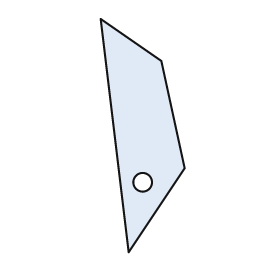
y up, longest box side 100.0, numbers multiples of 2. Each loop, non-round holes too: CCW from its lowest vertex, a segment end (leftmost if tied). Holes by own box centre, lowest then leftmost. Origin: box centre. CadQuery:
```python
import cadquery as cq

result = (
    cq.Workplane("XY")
    .moveTo(-6.0, -50.0)
    .lineTo(18.0, -14.0)
    .lineTo(8.0, 32.0)
    .lineTo(-18.0, 50.0)
    .close()
    .moveTo(0.0, -20.0)
    .circle(4.0)
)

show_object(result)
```